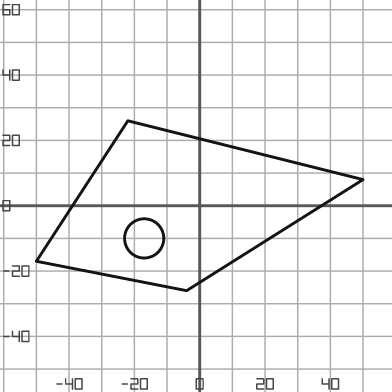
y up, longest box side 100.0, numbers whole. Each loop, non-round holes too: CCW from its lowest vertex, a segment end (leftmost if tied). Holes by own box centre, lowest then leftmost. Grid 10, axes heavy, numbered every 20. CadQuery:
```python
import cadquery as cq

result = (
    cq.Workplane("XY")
    .moveTo(-4.0, -26.0)
    .lineTo(50.0, 8.0)
    .lineTo(-22.0, 26.0)
    .lineTo(-50.0, -17.0)
    .close()
    .moveTo(-17.0, -10.0)
    .circle(6.0)
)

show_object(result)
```